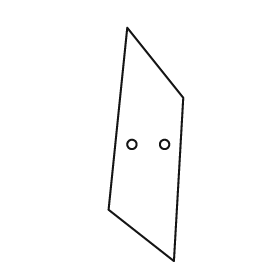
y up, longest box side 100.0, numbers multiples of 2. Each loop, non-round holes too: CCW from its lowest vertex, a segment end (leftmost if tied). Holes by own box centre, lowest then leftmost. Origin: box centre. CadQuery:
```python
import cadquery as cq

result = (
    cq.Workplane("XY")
    .moveTo(12.0, -50.0)
    .lineTo(16.0, 20.0)
    .lineTo(-8.0, 50.0)
    .lineTo(-16.0, -28.0)
    .close()
    .moveTo(-6.0, 0.0)
    .circle(2.0)
    .moveTo(8.0, 0.0)
    .circle(2.0)
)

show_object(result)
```